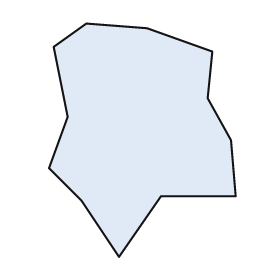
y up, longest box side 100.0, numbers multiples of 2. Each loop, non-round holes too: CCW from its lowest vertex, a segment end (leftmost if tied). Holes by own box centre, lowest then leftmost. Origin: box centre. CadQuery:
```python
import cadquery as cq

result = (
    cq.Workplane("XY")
    .moveTo(-10.0, -50.0)
    .lineTo(8.0, -24.0)
    .lineTo(40.0, -24.0)
    .lineTo(38.0, 0.0)
    .lineTo(28.0, 18.0)
    .lineTo(30.0, 38.0)
    .lineTo(2.0, 48.0)
    .lineTo(-24.0, 50.0)
    .lineTo(-38.0, 40.0)
    .lineTo(-32.0, 10.0)
    .lineTo(-40.0, -12.0)
    .lineTo(-26.0, -26.0)
    .close()
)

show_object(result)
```